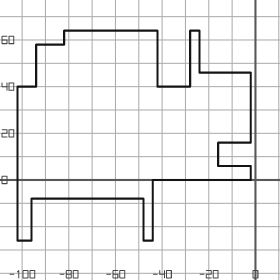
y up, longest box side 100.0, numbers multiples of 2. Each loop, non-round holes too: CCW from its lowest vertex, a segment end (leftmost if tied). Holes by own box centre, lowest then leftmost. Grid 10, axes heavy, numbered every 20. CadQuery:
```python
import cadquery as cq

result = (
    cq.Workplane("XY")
    .moveTo(-102.0, -26.0)
    .lineTo(-96.0, -26.0)
    .lineTo(-96.0, -8.0)
    .lineTo(-48.0, -8.0)
    .lineTo(-48.0, -26.0)
    .lineTo(-44.0, -26.0)
    .lineTo(-44.0, 0.0)
    .lineTo(-2.0, 0.0)
    .lineTo(-2.0, 6.0)
    .lineTo(-16.0, 6.0)
    .lineTo(-16.0, 16.0)
    .lineTo(-2.0, 16.0)
    .lineTo(-2.0, 46.0)
    .lineTo(-24.0, 46.0)
    .lineTo(-24.0, 64.0)
    .lineTo(-28.0, 64.0)
    .lineTo(-28.0, 40.0)
    .lineTo(-42.0, 40.0)
    .lineTo(-42.0, 64.0)
    .lineTo(-82.0, 64.0)
    .lineTo(-82.0, 58.0)
    .lineTo(-94.0, 58.0)
    .lineTo(-94.0, 40.0)
    .lineTo(-102.0, 40.0)
    .close()
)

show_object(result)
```